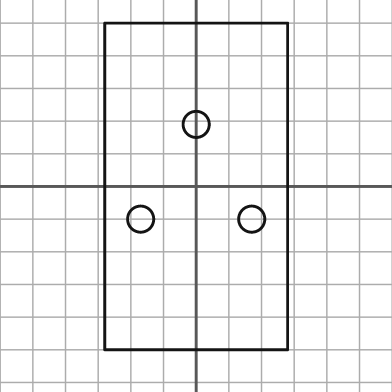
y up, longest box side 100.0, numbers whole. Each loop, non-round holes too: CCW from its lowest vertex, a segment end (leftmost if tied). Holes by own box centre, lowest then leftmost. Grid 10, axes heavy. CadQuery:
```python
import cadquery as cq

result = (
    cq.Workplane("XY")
    .moveTo(-28.0, -50.0)
    .lineTo(28.0, -50.0)
    .lineTo(28.0, 50.0)
    .lineTo(-28.0, 50.0)
    .close()
    .moveTo(-17.0, -10.0)
    .circle(4.0)
    .moveTo(17.0, -10.0)
    .circle(4.0)
    .moveTo(0.0, 19.0)
    .circle(4.0)
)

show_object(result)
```